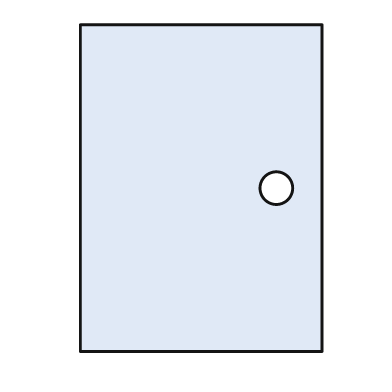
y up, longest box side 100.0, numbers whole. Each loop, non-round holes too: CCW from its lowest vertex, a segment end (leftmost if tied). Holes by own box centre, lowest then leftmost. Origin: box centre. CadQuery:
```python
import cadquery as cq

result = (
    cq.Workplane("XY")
    .moveTo(-37.0, -50.0)
    .lineTo(37.0, -50.0)
    .lineTo(37.0, 50.0)
    .lineTo(-37.0, 50.0)
    .close()
    .moveTo(23.0, 0.0)
    .circle(5.0)
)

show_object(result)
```